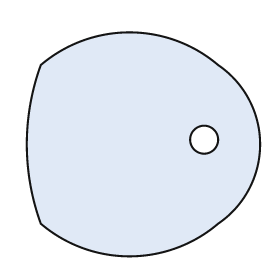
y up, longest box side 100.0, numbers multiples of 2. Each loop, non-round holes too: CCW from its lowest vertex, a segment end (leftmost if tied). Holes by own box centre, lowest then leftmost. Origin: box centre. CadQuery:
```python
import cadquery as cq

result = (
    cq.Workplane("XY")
    .moveTo(-44.0, -34.0)
    .threePointArc((-6.0, -48.0), (32.0, -34.0))
    .threePointArc((50.0, 0.0), (32.0, 34.0))
    .threePointArc((-6.0, 48.0), (-44.0, 34.0))
    .threePointArc((-50.0, 0.0), (-44.0, -34.0))
    .close()
    .moveTo(26.0, 2.0)
    .circle(6.0)
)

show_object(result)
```